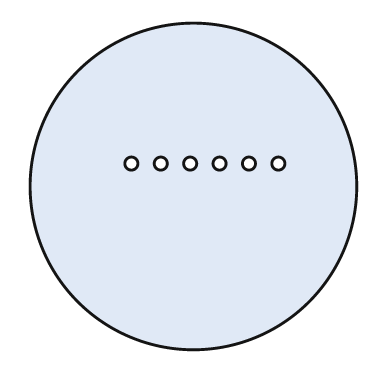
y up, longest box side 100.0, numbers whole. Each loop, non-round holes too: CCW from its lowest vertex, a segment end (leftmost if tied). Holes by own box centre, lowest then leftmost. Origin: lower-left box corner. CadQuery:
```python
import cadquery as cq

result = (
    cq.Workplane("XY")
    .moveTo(50.0, 50.0)
    .circle(50.0)
    .moveTo(31.0, 57.0)
    .circle(2.0)
    .moveTo(40.0, 57.0)
    .circle(2.0)
    .moveTo(49.0, 57.0)
    .circle(2.0)
    .moveTo(58.0, 57.0)
    .circle(2.0)
    .moveTo(67.0, 57.0)
    .circle(2.0)
    .moveTo(76.0, 57.0)
    .circle(2.0)
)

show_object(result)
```